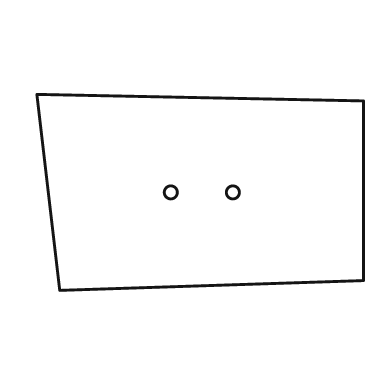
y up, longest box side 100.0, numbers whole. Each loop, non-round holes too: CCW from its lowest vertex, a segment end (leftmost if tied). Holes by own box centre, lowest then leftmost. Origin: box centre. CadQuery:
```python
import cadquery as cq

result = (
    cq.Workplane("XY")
    .moveTo(-43.0, -30.0)
    .lineTo(50.0, -27.0)
    .lineTo(50.0, 28.0)
    .lineTo(-50.0, 30.0)
    .close()
    .moveTo(-9.0, 0.0)
    .circle(2.0)
    .moveTo(10.0, 0.0)
    .circle(2.0)
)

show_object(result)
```